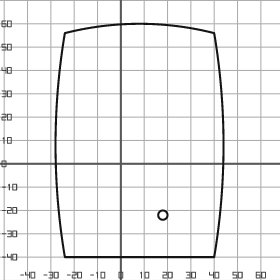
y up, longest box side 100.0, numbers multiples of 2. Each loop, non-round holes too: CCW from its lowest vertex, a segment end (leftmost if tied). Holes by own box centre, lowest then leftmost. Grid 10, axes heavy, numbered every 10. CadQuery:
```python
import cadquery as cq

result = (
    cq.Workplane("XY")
    .moveTo(-24.0, -40.0)
    .lineTo(40.0, -40.0)
    .threePointArc((44.0, 8.0), (40.0, 56.0))
    .threePointArc((8.0, 60.0), (-24.0, 56.0))
    .threePointArc((-28.0, 8.0), (-24.0, -40.0))
    .close()
    .moveTo(18.0, -22.0)
    .circle(2.0)
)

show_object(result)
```